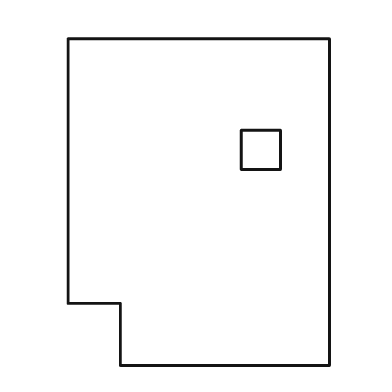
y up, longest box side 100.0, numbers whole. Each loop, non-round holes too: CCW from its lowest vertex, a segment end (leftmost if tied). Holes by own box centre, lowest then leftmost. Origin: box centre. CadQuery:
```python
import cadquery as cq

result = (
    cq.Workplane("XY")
    .moveTo(-24.0, -50.0)
    .lineTo(40.0, -50.0)
    .lineTo(40.0, 50.0)
    .lineTo(-40.0, 50.0)
    .lineTo(-40.0, -31.0)
    .lineTo(-24.0, -31.0)
    .close()
    .moveTo(13.0, 10.0)
    .lineTo(25.0, 10.0)
    .lineTo(25.0, 22.0)
    .lineTo(13.0, 22.0)
    .close()
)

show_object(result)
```